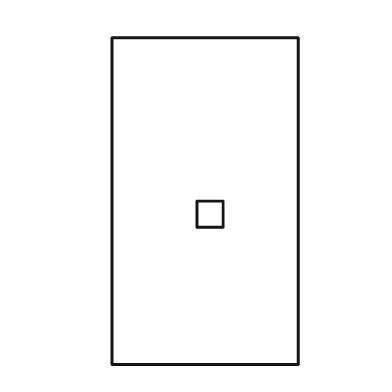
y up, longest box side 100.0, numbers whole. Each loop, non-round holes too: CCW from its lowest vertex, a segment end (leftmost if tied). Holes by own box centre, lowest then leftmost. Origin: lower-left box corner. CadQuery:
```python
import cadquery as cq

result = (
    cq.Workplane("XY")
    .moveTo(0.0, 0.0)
    .lineTo(57.0, 0.0)
    .lineTo(57.0, 100.0)
    .lineTo(0.0, 100.0)
    .close()
    .moveTo(26.0, 42.0)
    .lineTo(34.0, 42.0)
    .lineTo(34.0, 50.0)
    .lineTo(26.0, 50.0)
    .close()
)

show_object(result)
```